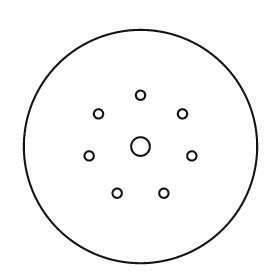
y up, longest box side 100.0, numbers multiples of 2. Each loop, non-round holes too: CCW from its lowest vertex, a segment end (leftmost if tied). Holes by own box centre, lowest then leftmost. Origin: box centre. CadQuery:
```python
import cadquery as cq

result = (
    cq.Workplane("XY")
    .moveTo(0.0, 0.0)
    .circle(50.0)
    .moveTo(-10.0, -20.0)
    .circle(2.0)
    .moveTo(10.0, -20.0)
    .circle(2.0)
    .moveTo(-22.0, -4.0)
    .circle(2.0)
    .moveTo(22.0, -4.0)
    .circle(2.0)
    .moveTo(0.0, 0.0)
    .circle(4.0)
    .moveTo(-18.0, 14.0)
    .circle(2.0)
    .moveTo(18.0, 14.0)
    .circle(2.0)
    .moveTo(0.0, 22.0)
    .circle(2.0)
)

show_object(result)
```